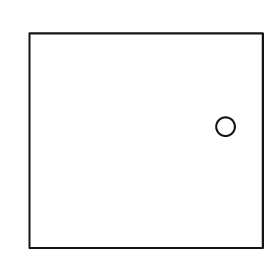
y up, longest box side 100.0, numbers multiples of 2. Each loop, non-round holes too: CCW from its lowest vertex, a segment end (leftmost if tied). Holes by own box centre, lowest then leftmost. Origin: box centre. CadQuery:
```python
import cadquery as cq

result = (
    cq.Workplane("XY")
    .moveTo(-50.0, -46.0)
    .lineTo(50.0, -46.0)
    .lineTo(50.0, 46.0)
    .lineTo(-50.0, 46.0)
    .close()
    .moveTo(34.0, 6.0)
    .circle(4.0)
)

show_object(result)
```